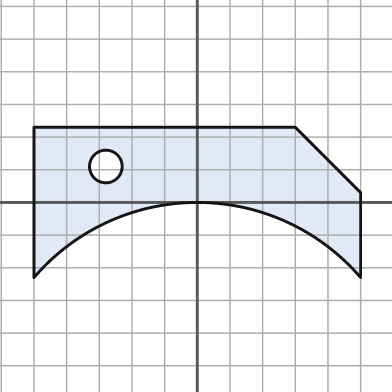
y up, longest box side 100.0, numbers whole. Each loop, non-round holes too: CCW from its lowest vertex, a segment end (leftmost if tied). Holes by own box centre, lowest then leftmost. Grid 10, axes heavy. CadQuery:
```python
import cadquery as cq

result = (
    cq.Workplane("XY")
    .moveTo(-50.0, -23.0)
    .threePointArc((0.0, 0.0), (50.0, -23.0))
    .lineTo(50.0, 3.0)
    .lineTo(30.0, 23.0)
    .lineTo(-50.0, 23.0)
    .close()
    .moveTo(-28.0, 11.0)
    .circle(5.0)
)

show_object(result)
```